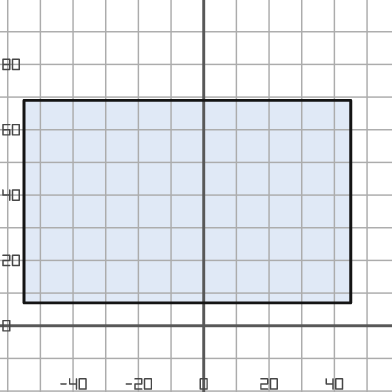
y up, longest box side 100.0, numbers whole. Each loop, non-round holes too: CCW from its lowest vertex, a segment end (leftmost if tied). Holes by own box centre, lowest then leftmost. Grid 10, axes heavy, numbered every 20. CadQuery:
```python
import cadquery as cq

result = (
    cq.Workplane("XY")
    .moveTo(-55.0, 7.0)
    .lineTo(45.0, 7.0)
    .lineTo(45.0, 69.0)
    .lineTo(-55.0, 69.0)
    .close()
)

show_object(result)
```